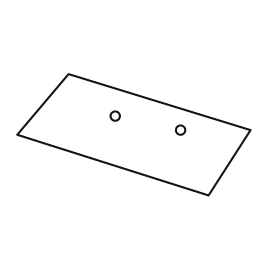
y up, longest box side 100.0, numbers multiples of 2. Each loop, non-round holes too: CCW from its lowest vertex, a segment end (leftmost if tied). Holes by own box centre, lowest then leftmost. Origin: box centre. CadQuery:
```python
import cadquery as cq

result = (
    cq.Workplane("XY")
    .moveTo(32.0, -26.0)
    .lineTo(50.0, 2.0)
    .lineTo(-28.0, 26.0)
    .lineTo(-50.0, 0.0)
    .close()
    .moveTo(20.0, 2.0)
    .circle(2.0)
    .moveTo(-8.0, 8.0)
    .circle(2.0)
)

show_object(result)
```